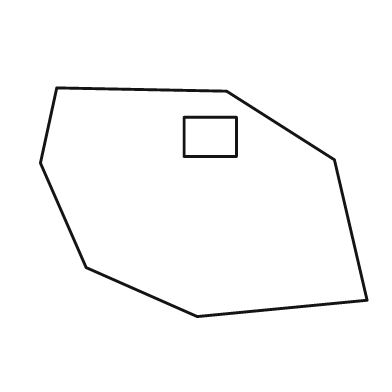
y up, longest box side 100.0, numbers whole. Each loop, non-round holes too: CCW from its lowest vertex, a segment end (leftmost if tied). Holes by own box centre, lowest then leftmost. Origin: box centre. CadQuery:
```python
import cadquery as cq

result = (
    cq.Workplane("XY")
    .moveTo(-2.0, -35.0)
    .lineTo(50.0, -30.0)
    .lineTo(40.0, 13.0)
    .lineTo(7.0, 34.0)
    .lineTo(-45.0, 35.0)
    .lineTo(-50.0, 12.0)
    .lineTo(-36.0, -20.0)
    .close()
    .moveTo(-6.0, 14.0)
    .lineTo(10.0, 14.0)
    .lineTo(10.0, 26.0)
    .lineTo(-6.0, 26.0)
    .close()
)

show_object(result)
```